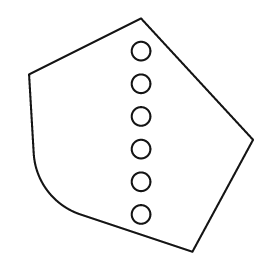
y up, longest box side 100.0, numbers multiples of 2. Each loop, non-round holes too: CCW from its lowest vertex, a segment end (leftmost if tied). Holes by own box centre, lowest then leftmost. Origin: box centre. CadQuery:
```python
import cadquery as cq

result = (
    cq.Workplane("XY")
    .moveTo(22.0, -50.0)
    .lineTo(48.0, -2.0)
    .lineTo(0.0, 50.0)
    .lineTo(-48.0, 26.0)
    .lineTo(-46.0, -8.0)
    .threePointArc((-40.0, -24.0), (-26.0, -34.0))
    .close()
    .moveTo(0.0, -34.0)
    .circle(4.0)
    .moveTo(0.0, -20.0)
    .circle(4.0)
    .moveTo(0.0, -6.0)
    .circle(4.0)
    .moveTo(0.0, 8.0)
    .circle(4.0)
    .moveTo(0.0, 22.0)
    .circle(4.0)
    .moveTo(0.0, 36.0)
    .circle(4.0)
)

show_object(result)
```